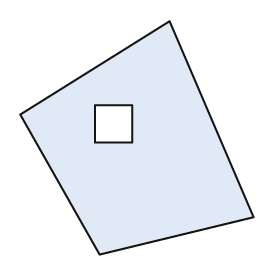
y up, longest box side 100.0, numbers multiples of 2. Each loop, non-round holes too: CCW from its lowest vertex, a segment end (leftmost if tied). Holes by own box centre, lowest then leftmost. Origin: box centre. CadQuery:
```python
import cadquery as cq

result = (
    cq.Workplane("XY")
    .moveTo(-16.0, -50.0)
    .lineTo(50.0, -34.0)
    .lineTo(14.0, 50.0)
    .lineTo(-50.0, 10.0)
    .close()
    .moveTo(-18.0, -2.0)
    .lineTo(-2.0, -2.0)
    .lineTo(-2.0, 14.0)
    .lineTo(-18.0, 14.0)
    .close()
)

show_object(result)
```